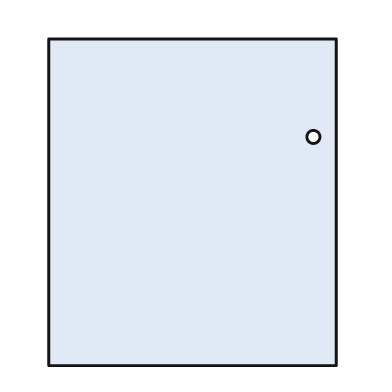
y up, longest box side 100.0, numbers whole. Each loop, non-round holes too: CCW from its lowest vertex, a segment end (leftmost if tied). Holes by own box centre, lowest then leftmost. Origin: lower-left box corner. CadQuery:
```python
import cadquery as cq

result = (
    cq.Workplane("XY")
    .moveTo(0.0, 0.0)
    .lineTo(88.0, 0.0)
    .lineTo(88.0, 100.0)
    .lineTo(0.0, 100.0)
    .close()
    .moveTo(81.0, 70.0)
    .circle(2.0)
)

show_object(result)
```